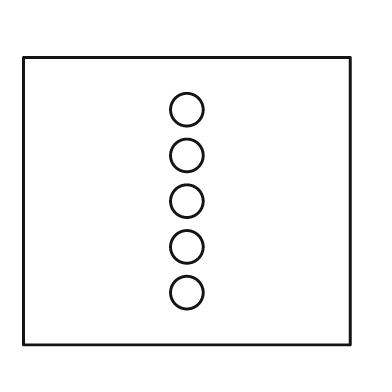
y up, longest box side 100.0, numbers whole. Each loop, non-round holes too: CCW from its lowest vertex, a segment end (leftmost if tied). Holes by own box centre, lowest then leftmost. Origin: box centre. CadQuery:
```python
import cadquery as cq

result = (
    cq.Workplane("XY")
    .moveTo(-50.0, -44.0)
    .lineTo(50.0, -44.0)
    .lineTo(50.0, 44.0)
    .lineTo(-50.0, 44.0)
    .close()
    .moveTo(0.0, -28.0)
    .circle(5.0)
    .moveTo(0.0, -14.0)
    .circle(5.0)
    .moveTo(0.0, 0.0)
    .circle(5.0)
    .moveTo(0.0, 14.0)
    .circle(5.0)
    .moveTo(0.0, 28.0)
    .circle(5.0)
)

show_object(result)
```